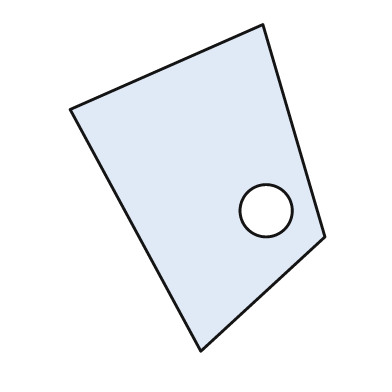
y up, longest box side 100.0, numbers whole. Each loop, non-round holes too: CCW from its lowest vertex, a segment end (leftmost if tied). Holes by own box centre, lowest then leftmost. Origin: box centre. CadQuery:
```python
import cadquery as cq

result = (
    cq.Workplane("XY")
    .moveTo(1.0, -50.0)
    .lineTo(39.0, -15.0)
    .lineTo(20.0, 50.0)
    .lineTo(-39.0, 24.0)
    .close()
    .moveTo(21.0, -7.0)
    .circle(8.0)
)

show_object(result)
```